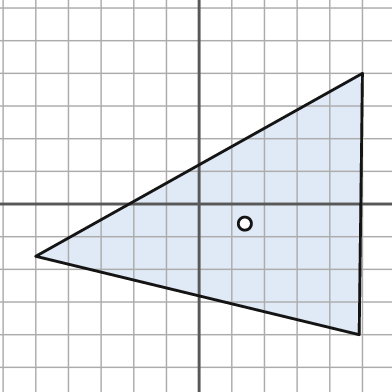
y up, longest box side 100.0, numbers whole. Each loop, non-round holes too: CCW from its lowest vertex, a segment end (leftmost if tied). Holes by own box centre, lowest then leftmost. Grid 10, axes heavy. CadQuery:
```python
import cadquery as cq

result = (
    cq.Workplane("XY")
    .moveTo(49.0, -40.0)
    .lineTo(50.0, 40.0)
    .lineTo(-50.0, -16.0)
    .close()
    .moveTo(14.0, -6.0)
    .circle(2.0)
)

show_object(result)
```